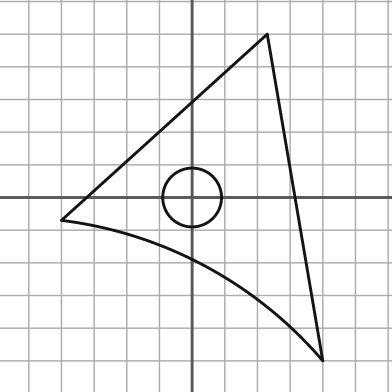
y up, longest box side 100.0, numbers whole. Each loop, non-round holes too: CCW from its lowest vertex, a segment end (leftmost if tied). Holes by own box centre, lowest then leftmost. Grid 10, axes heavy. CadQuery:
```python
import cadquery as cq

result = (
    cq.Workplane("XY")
    .moveTo(40.0, -50.0)
    .lineTo(23.0, 50.0)
    .lineTo(-40.0, -7.0)
    .threePointArc((4.0, -21.0), (40.0, -50.0))
    .close()
    .moveTo(0.0, 0.0)
    .circle(9.0)
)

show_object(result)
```